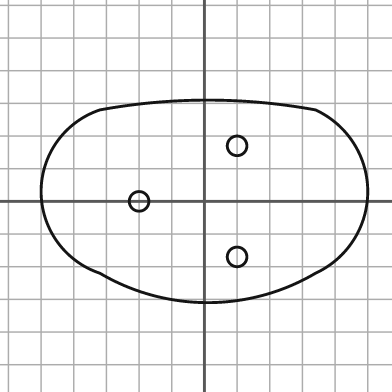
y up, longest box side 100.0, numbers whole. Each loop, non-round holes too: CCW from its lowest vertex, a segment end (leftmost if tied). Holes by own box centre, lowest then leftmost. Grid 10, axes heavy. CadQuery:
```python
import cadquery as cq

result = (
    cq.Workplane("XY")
    .moveTo(-32.0, -22.0)
    .threePointArc((1.0, -31.0), (34.0, -22.0))
    .threePointArc((50.0, 3.0), (34.0, 28.0))
    .threePointArc((1.0, 31.0), (-32.0, 28.0))
    .threePointArc((-50.0, 3.0), (-32.0, -22.0))
    .close()
    .moveTo(10.0, -17.0)
    .circle(3.0)
    .moveTo(-20.0, 0.0)
    .circle(3.0)
    .moveTo(10.0, 17.0)
    .circle(3.0)
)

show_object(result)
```